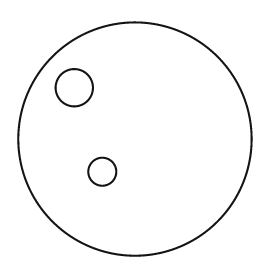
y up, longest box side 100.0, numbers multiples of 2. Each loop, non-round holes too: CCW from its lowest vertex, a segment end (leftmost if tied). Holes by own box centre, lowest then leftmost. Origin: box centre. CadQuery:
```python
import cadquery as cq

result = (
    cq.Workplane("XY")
    .moveTo(0.0, 0.0)
    .circle(50.0)
    .moveTo(-14.0, -14.0)
    .circle(6.0)
    .moveTo(-26.0, 22.0)
    .circle(8.0)
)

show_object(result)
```